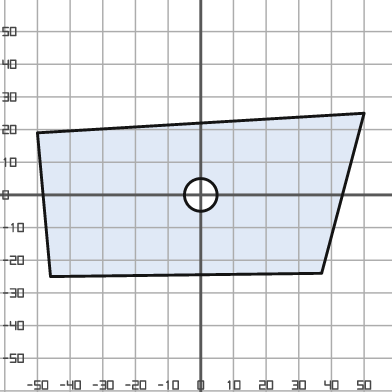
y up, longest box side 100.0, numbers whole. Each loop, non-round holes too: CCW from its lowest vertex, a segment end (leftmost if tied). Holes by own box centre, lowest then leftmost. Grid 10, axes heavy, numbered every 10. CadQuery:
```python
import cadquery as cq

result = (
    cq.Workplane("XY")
    .moveTo(-46.0, -25.0)
    .lineTo(37.0, -24.0)
    .lineTo(50.0, 25.0)
    .lineTo(-50.0, 19.0)
    .close()
    .moveTo(0.0, 0.0)
    .circle(5.0)
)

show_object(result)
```